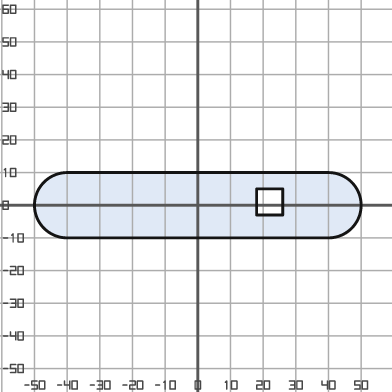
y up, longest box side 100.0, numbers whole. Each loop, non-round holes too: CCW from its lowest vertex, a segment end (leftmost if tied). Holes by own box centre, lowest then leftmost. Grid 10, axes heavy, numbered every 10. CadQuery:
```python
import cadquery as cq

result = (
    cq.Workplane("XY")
    .moveTo(-40.0, -10.0)
    .lineTo(40.0, -10.0)
    .threePointArc((50.0, 0.0), (40.0, 10.0))
    .lineTo(-40.0, 10.0)
    .threePointArc((-50.0, 0.0), (-40.0, -10.0))
    .close()
    .moveTo(18.0, -3.0)
    .lineTo(26.0, -3.0)
    .lineTo(26.0, 5.0)
    .lineTo(18.0, 5.0)
    .close()
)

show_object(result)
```